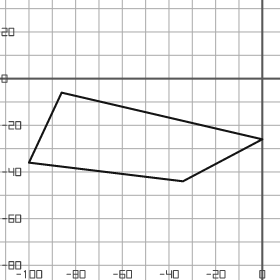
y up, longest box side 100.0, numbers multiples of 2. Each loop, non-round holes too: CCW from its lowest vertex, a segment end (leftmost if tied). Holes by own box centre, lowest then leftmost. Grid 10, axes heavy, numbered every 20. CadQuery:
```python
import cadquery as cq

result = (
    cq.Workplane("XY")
    .moveTo(-34.0, -44.0)
    .lineTo(0.0, -26.0)
    .lineTo(-86.0, -6.0)
    .lineTo(-100.0, -36.0)
    .close()
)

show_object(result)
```